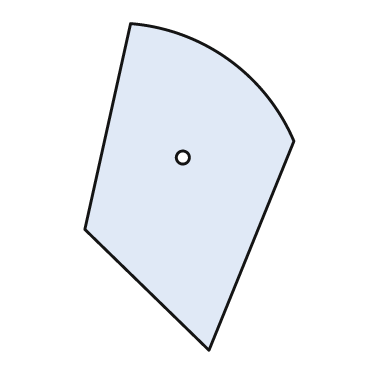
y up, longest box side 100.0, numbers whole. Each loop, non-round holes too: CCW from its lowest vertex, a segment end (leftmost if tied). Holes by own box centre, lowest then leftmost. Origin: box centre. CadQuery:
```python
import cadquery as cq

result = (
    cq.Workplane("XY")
    .moveTo(6.0, -50.0)
    .lineTo(32.0, 14.0)
    .threePointArc((12.0, 39.0), (-18.0, 50.0))
    .lineTo(-32.0, -13.0)
    .close()
    .moveTo(-2.0, 9.0)
    .circle(2.0)
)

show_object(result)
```